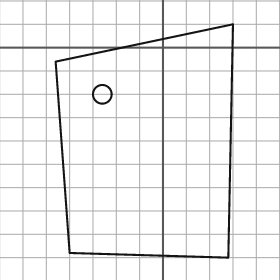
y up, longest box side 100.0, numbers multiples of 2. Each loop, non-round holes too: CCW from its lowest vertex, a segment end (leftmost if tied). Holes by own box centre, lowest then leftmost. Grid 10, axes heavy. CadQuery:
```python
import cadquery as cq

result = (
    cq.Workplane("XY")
    .moveTo(28.0, -90.0)
    .lineTo(30.0, 10.0)
    .lineTo(-46.0, -6.0)
    .lineTo(-40.0, -88.0)
    .close()
    .moveTo(-26.0, -20.0)
    .circle(4.0)
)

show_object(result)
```